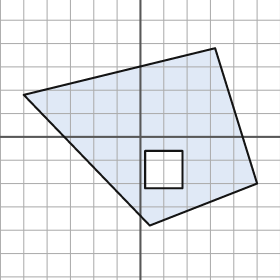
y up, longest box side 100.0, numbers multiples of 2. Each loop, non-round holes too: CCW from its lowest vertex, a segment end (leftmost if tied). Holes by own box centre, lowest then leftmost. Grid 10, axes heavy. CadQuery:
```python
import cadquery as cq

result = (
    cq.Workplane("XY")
    .moveTo(4.0, -38.0)
    .lineTo(50.0, -20.0)
    .lineTo(32.0, 38.0)
    .lineTo(-50.0, 18.0)
    .close()
    .moveTo(2.0, -22.0)
    .lineTo(18.0, -22.0)
    .lineTo(18.0, -6.0)
    .lineTo(2.0, -6.0)
    .close()
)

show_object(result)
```